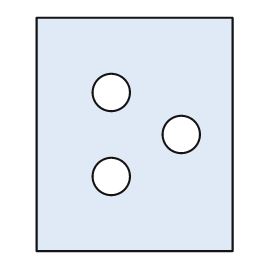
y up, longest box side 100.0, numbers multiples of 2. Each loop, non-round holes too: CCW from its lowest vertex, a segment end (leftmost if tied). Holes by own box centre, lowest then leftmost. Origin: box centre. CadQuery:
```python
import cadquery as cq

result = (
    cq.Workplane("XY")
    .moveTo(-42.0, -50.0)
    .lineTo(42.0, -50.0)
    .lineTo(42.0, 50.0)
    .lineTo(-42.0, 50.0)
    .close()
    .moveTo(-10.0, -18.0)
    .circle(8.0)
    .moveTo(20.0, 0.0)
    .circle(8.0)
    .moveTo(-10.0, 18.0)
    .circle(8.0)
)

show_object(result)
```